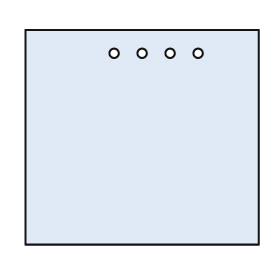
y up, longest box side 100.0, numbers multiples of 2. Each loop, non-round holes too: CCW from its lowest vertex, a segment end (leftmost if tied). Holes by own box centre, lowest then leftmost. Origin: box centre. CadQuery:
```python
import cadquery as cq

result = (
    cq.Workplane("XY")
    .moveTo(-50.0, -46.0)
    .lineTo(50.0, -46.0)
    .lineTo(50.0, 46.0)
    .lineTo(-50.0, 46.0)
    .close()
    .moveTo(-12.0, 36.0)
    .circle(2.0)
    .moveTo(0.0, 36.0)
    .circle(2.0)
    .moveTo(12.0, 36.0)
    .circle(2.0)
    .moveTo(24.0, 36.0)
    .circle(2.0)
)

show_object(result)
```